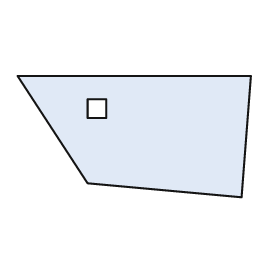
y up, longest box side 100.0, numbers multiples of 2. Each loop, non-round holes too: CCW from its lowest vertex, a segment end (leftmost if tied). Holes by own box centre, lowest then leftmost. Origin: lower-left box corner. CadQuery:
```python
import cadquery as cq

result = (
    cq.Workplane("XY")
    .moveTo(96.0, 0.0)
    .lineTo(100.0, 52.0)
    .lineTo(0.0, 52.0)
    .lineTo(30.0, 6.0)
    .close()
    .moveTo(30.0, 34.0)
    .lineTo(38.0, 34.0)
    .lineTo(38.0, 42.0)
    .lineTo(30.0, 42.0)
    .close()
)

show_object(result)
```